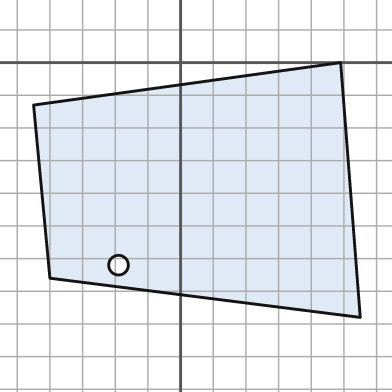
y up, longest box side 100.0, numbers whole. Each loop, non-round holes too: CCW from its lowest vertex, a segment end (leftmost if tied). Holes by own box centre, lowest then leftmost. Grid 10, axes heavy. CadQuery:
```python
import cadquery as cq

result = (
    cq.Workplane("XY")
    .moveTo(55.0, -78.0)
    .lineTo(49.0, 0.0)
    .lineTo(-45.0, -13.0)
    .lineTo(-40.0, -66.0)
    .close()
    .moveTo(-19.0, -62.0)
    .circle(3.0)
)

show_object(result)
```